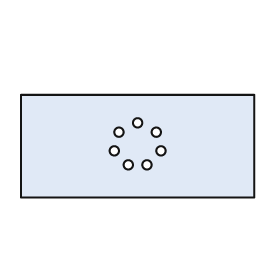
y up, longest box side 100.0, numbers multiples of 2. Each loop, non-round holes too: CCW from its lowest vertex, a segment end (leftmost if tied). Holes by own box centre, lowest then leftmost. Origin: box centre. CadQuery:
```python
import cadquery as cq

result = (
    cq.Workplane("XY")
    .moveTo(-50.0, -22.0)
    .lineTo(50.0, -22.0)
    .lineTo(50.0, 22.0)
    .lineTo(-50.0, 22.0)
    .close()
    .moveTo(-4.0, -8.0)
    .circle(2.0)
    .moveTo(4.0, -8.0)
    .circle(2.0)
    .moveTo(-10.0, -2.0)
    .circle(2.0)
    .moveTo(10.0, -2.0)
    .circle(2.0)
    .moveTo(-8.0, 6.0)
    .circle(2.0)
    .moveTo(8.0, 6.0)
    .circle(2.0)
    .moveTo(0.0, 10.0)
    .circle(2.0)
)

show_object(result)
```